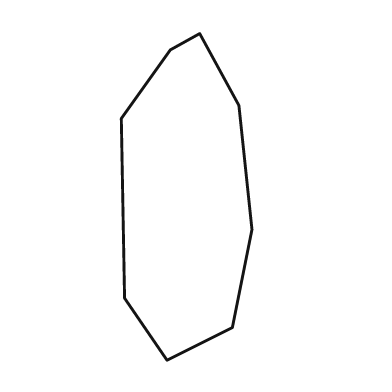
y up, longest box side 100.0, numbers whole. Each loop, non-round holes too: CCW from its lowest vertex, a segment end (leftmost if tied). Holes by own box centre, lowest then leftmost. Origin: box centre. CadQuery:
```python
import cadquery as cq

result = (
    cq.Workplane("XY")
    .moveTo(-6.0, -50.0)
    .lineTo(14.0, -40.0)
    .lineTo(20.0, -10.0)
    .lineTo(16.0, 28.0)
    .lineTo(4.0, 50.0)
    .lineTo(-5.0, 45.0)
    .lineTo(-20.0, 24.0)
    .lineTo(-19.0, -31.0)
    .close()
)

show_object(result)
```